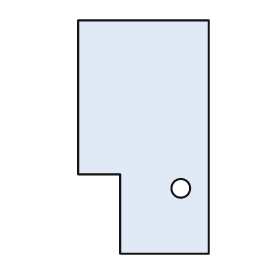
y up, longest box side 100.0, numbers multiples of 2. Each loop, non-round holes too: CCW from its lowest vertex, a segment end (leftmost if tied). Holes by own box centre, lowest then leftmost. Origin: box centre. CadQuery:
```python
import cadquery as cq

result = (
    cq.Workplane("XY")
    .moveTo(-10.0, -50.0)
    .lineTo(28.0, -50.0)
    .lineTo(28.0, 50.0)
    .lineTo(-28.0, 50.0)
    .lineTo(-28.0, -16.0)
    .lineTo(-10.0, -16.0)
    .close()
    .moveTo(16.0, -22.0)
    .circle(4.0)
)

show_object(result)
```